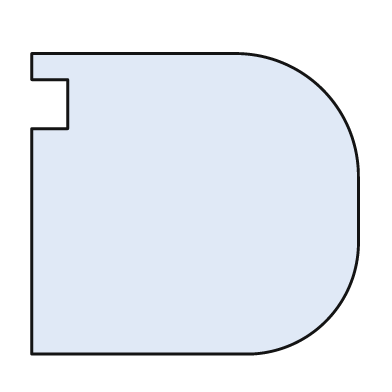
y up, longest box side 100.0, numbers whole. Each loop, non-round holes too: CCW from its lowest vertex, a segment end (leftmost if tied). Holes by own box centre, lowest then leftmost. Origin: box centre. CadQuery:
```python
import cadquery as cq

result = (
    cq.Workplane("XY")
    .moveTo(-50.0, -46.0)
    .lineTo(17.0, -46.0)
    .threePointArc((40.0, -36.0), (50.0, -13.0))
    .lineTo(50.0, 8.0)
    .threePointArc((39.0, 35.0), (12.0, 46.0))
    .lineTo(-50.0, 46.0)
    .lineTo(-50.0, 38.0)
    .lineTo(-39.0, 38.0)
    .lineTo(-39.0, 23.0)
    .lineTo(-50.0, 23.0)
    .close()
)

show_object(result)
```